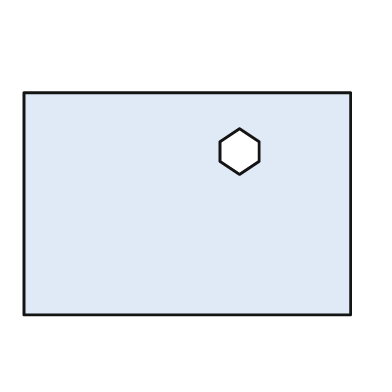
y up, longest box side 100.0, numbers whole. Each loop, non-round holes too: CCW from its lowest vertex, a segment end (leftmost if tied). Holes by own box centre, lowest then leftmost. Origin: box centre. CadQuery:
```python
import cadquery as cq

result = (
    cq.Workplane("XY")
    .moveTo(-50.0, -34.0)
    .lineTo(50.0, -34.0)
    .lineTo(50.0, 34.0)
    .lineTo(-50.0, 34.0)
    .close()
    .moveTo(16.0, 9.0)
    .lineTo(22.0, 13.0)
    .lineTo(22.0, 19.0)
    .lineTo(16.0, 23.0)
    .lineTo(10.0, 19.0)
    .lineTo(10.0, 13.0)
    .close()
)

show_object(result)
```